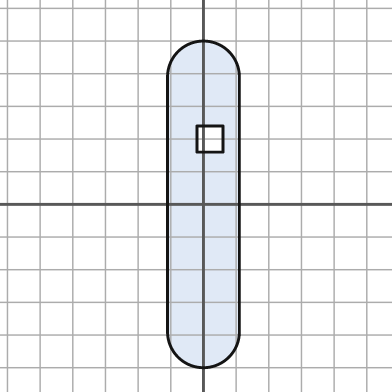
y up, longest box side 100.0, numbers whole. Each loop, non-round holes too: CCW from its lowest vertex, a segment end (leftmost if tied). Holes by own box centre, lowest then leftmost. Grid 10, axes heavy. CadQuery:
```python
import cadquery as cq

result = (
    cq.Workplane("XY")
    .moveTo(-11.0, -39.0)
    .threePointArc((0.0, -50.0), (11.0, -39.0))
    .lineTo(11.0, 39.0)
    .threePointArc((0.0, 50.0), (-11.0, 39.0))
    .close()
    .moveTo(-2.0, 16.0)
    .lineTo(6.0, 16.0)
    .lineTo(6.0, 24.0)
    .lineTo(-2.0, 24.0)
    .close()
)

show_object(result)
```